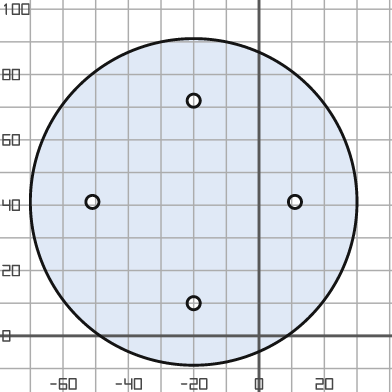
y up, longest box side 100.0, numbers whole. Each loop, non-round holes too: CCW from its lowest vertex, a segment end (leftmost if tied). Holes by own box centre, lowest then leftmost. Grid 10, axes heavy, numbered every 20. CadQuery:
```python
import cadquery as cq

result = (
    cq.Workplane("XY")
    .moveTo(-20.0, 41.0)
    .circle(50.0)
    .moveTo(-20.0, 10.0)
    .circle(2.0)
    .moveTo(-51.0, 41.0)
    .circle(2.0)
    .moveTo(11.0, 41.0)
    .circle(2.0)
    .moveTo(-20.0, 72.0)
    .circle(2.0)
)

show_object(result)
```